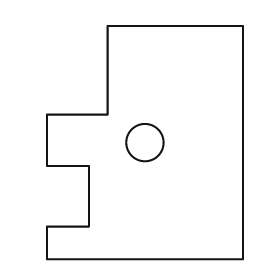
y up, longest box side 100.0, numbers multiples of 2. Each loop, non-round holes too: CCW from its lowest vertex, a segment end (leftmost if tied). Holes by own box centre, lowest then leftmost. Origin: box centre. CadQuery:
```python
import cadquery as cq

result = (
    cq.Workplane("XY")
    .moveTo(-42.0, -50.0)
    .lineTo(42.0, -50.0)
    .lineTo(42.0, 50.0)
    .lineTo(-16.0, 50.0)
    .lineTo(-16.0, 12.0)
    .lineTo(-42.0, 12.0)
    .lineTo(-42.0, -10.0)
    .lineTo(-24.0, -10.0)
    .lineTo(-24.0, -36.0)
    .lineTo(-42.0, -36.0)
    .close()
    .moveTo(0.0, 0.0)
    .circle(8.0)
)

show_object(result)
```